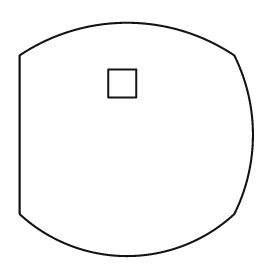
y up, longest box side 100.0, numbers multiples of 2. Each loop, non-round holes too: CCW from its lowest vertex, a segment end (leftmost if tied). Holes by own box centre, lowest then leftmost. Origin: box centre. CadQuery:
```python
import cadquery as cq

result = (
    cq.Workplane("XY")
    .moveTo(-50.0, -32.0)
    .threePointArc((-4.0, -50.0), (42.0, -32.0))
    .threePointArc((50.0, 2.0), (42.0, 36.0))
    .threePointArc((-4.0, 50.0), (-50.0, 36.0))
    .close()
    .moveTo(-12.0, 18.0)
    .lineTo(0.0, 18.0)
    .lineTo(0.0, 30.0)
    .lineTo(-12.0, 30.0)
    .close()
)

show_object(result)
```